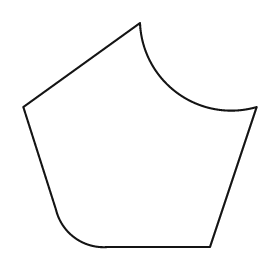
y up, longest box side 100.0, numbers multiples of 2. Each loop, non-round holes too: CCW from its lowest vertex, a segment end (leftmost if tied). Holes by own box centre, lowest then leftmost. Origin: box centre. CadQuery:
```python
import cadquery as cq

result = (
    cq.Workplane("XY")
    .moveTo(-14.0, -48.0)
    .lineTo(30.0, -48.0)
    .lineTo(50.0, 12.0)
    .threePointArc((16.0, 18.0), (0.0, 48.0))
    .lineTo(-50.0, 12.0)
    .lineTo(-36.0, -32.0)
    .threePointArc((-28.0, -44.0), (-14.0, -48.0))
    .close()
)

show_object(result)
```